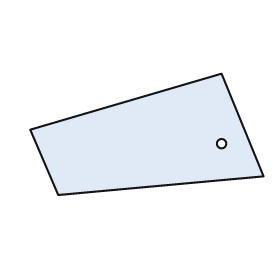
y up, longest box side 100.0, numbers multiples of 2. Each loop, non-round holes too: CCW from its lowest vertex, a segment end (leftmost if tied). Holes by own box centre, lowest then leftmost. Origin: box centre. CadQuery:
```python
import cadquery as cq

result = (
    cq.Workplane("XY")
    .moveTo(-38.0, -26.0)
    .lineTo(50.0, -18.0)
    .lineTo(32.0, 26.0)
    .lineTo(-50.0, 2.0)
    .close()
    .moveTo(32.0, -4.0)
    .circle(2.0)
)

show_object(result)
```